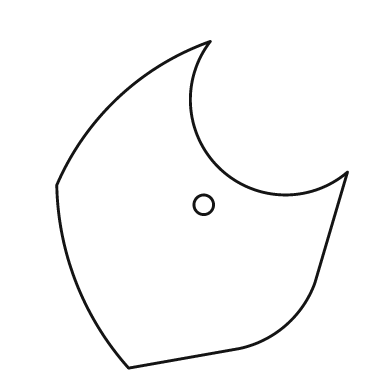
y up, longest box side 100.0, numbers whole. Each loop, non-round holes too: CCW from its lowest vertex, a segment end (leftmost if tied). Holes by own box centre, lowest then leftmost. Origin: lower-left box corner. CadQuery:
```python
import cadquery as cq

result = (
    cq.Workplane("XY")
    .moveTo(22.0, 0.0)
    .lineTo(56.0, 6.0)
    .threePointArc((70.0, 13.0), (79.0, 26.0))
    .lineTo(89.0, 60.0)
    .threePointArc((50.0, 61.0), (47.0, 100.0))
    .threePointArc((19.0, 83.0), (0.0, 56.0))
    .threePointArc((6.0, 26.0), (22.0, 0.0))
    .close()
    .moveTo(45.0, 50.0)
    .circle(3.0)
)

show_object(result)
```